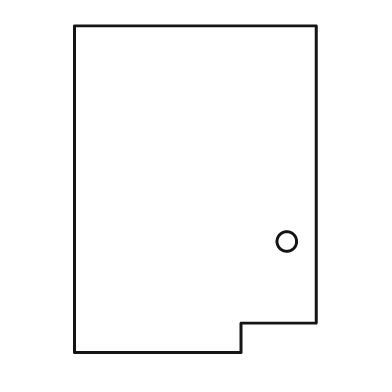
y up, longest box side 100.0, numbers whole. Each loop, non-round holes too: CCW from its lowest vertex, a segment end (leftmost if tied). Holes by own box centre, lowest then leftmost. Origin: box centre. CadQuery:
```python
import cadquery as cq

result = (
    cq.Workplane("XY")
    .moveTo(-37.0, -50.0)
    .lineTo(14.0, -50.0)
    .lineTo(14.0, -41.0)
    .lineTo(37.0, -41.0)
    .lineTo(37.0, 50.0)
    .lineTo(-37.0, 50.0)
    .close()
    .moveTo(28.0, -16.0)
    .circle(3.0)
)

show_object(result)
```